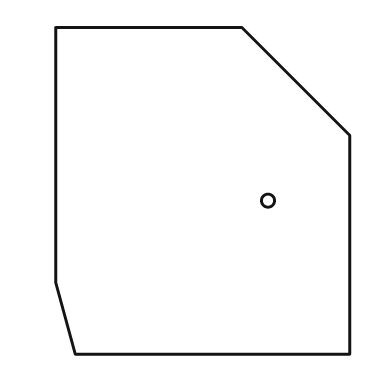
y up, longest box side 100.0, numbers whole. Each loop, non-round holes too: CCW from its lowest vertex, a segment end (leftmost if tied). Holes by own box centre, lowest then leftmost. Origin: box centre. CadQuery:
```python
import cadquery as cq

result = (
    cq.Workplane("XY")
    .moveTo(-39.0, -50.0)
    .lineTo(45.0, -50.0)
    .lineTo(45.0, 17.0)
    .lineTo(12.0, 50.0)
    .lineTo(-45.0, 50.0)
    .lineTo(-45.0, -28.0)
    .close()
    .moveTo(20.0, -3.0)
    .circle(2.0)
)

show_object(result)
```